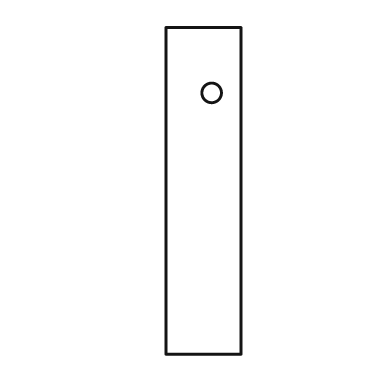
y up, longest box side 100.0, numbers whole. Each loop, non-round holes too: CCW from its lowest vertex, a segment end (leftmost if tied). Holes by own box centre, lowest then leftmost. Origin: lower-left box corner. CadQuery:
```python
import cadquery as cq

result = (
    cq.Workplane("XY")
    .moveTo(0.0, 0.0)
    .lineTo(23.0, 0.0)
    .lineTo(23.0, 100.0)
    .lineTo(0.0, 100.0)
    .close()
    .moveTo(14.0, 80.0)
    .circle(3.0)
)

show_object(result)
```